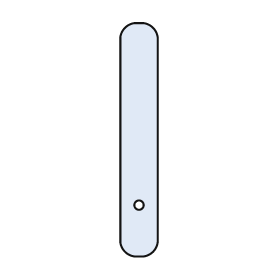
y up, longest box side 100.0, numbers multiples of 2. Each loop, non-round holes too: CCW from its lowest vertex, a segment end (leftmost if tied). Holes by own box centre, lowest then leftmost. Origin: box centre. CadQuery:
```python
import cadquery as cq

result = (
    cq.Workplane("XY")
    .moveTo(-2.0, -50.0)
    .lineTo(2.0, -50.0)
    .threePointArc((6.0, -48.0), (8.0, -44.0))
    .lineTo(8.0, 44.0)
    .threePointArc((6.0, 48.0), (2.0, 50.0))
    .lineTo(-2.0, 50.0)
    .threePointArc((-6.0, 48.0), (-8.0, 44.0))
    .lineTo(-8.0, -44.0)
    .threePointArc((-6.0, -48.0), (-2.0, -50.0))
    .close()
    .moveTo(0.0, -28.0)
    .circle(2.0)
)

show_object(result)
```